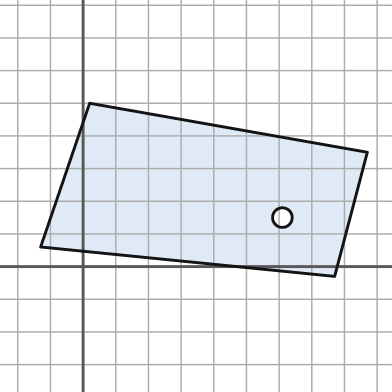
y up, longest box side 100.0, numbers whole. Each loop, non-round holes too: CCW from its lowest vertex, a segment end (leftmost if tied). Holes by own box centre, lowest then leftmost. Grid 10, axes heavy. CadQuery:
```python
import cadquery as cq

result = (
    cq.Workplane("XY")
    .moveTo(77.0, -3.0)
    .lineTo(87.0, 35.0)
    .lineTo(2.0, 50.0)
    .lineTo(-13.0, 6.0)
    .close()
    .moveTo(61.0, 15.0)
    .circle(3.0)
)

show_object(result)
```